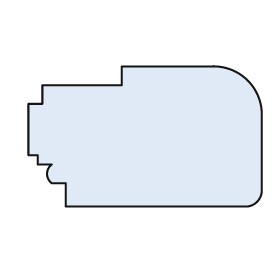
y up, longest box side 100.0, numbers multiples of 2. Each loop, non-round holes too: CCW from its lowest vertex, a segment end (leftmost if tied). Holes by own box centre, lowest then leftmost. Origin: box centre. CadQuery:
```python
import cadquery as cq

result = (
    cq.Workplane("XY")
    .moveTo(-34.0, -30.0)
    .lineTo(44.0, -30.0)
    .threePointArc((48.0, -28.0), (50.0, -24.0))
    .lineTo(50.0, 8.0)
    .threePointArc((44.0, 24.0), (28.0, 30.0))
    .lineTo(-10.0, 30.0)
    .lineTo(-10.0, 22.0)
    .lineTo(-44.0, 22.0)
    .lineTo(-44.0, 14.0)
    .lineTo(-50.0, 14.0)
    .lineTo(-50.0, -8.0)
    .lineTo(-46.0, -8.0)
    .lineTo(-46.0, -12.0)
    .lineTo(-40.0, -12.0)
    .threePointArc((-42.0, -16.0), (-40.0, -20.0))
    .lineTo(-34.0, -20.0)
    .close()
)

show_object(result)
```